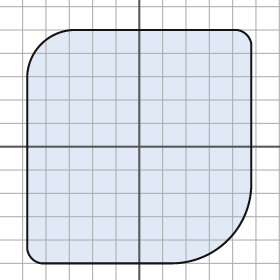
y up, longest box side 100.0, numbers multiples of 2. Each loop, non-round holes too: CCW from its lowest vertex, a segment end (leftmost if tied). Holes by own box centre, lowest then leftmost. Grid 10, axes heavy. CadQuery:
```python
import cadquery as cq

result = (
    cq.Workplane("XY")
    .moveTo(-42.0, -50.0)
    .lineTo(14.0, -50.0)
    .threePointArc((38.0, -40.0), (48.0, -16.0))
    .lineTo(48.0, 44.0)
    .threePointArc((46.0, 48.0), (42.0, 50.0))
    .lineTo(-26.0, 50.0)
    .threePointArc((-42.0, 44.0), (-48.0, 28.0))
    .lineTo(-48.0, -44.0)
    .threePointArc((-46.0, -48.0), (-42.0, -50.0))
    .close()
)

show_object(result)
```